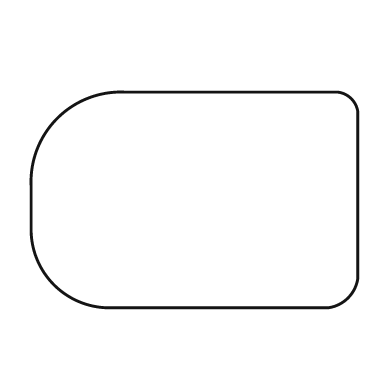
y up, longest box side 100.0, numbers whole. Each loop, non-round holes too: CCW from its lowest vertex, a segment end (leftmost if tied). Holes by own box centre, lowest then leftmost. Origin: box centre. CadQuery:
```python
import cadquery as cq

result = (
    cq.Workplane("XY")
    .moveTo(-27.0, -33.0)
    .lineTo(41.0, -33.0)
    .threePointArc((47.0, -30.0), (50.0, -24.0))
    .lineTo(50.0, 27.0)
    .threePointArc((48.0, 31.0), (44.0, 33.0))
    .lineTo(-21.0, 33.0)
    .threePointArc((-42.0, 25.0), (-50.0, 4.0))
    .lineTo(-50.0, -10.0)
    .threePointArc((-43.0, -26.0), (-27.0, -33.0))
    .close()
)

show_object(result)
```